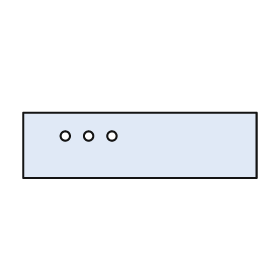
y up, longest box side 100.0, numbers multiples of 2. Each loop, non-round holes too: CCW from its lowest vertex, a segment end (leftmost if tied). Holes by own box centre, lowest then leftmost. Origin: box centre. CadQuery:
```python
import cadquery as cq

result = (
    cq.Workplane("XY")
    .moveTo(-50.0, -14.0)
    .lineTo(50.0, -14.0)
    .lineTo(50.0, 14.0)
    .lineTo(-50.0, 14.0)
    .close()
    .moveTo(-32.0, 4.0)
    .circle(2.0)
    .moveTo(-22.0, 4.0)
    .circle(2.0)
    .moveTo(-12.0, 4.0)
    .circle(2.0)
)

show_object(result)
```